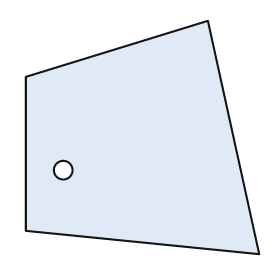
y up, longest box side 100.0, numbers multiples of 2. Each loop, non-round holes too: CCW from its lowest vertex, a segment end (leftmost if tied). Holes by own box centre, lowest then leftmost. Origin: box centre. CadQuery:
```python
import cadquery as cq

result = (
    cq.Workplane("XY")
    .moveTo(50.0, -50.0)
    .lineTo(28.0, 50.0)
    .lineTo(-50.0, 26.0)
    .lineTo(-50.0, -40.0)
    .close()
    .moveTo(-34.0, -14.0)
    .circle(4.0)
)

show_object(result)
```